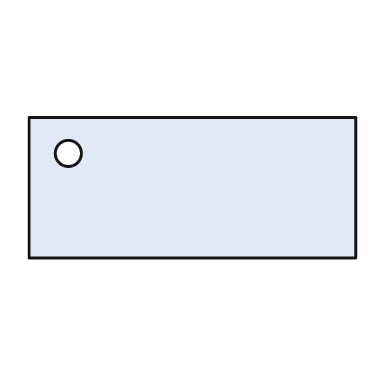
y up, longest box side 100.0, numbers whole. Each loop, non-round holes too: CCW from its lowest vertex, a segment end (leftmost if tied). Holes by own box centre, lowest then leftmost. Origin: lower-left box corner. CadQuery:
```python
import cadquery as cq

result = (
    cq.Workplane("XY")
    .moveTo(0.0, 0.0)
    .lineTo(100.0, 0.0)
    .lineTo(100.0, 43.0)
    .lineTo(0.0, 43.0)
    .close()
    .moveTo(12.0, 32.0)
    .circle(4.0)
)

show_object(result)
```